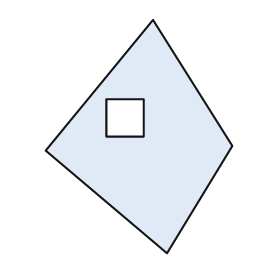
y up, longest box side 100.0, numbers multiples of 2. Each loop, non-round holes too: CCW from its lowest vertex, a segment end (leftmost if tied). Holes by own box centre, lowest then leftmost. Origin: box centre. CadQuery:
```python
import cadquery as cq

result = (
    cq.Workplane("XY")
    .moveTo(12.0, -50.0)
    .lineTo(40.0, -4.0)
    .lineTo(6.0, 50.0)
    .lineTo(-40.0, -6.0)
    .close()
    .moveTo(-14.0, 0.0)
    .lineTo(2.0, 0.0)
    .lineTo(2.0, 16.0)
    .lineTo(-14.0, 16.0)
    .close()
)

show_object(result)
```